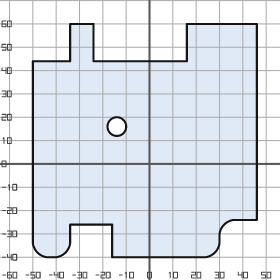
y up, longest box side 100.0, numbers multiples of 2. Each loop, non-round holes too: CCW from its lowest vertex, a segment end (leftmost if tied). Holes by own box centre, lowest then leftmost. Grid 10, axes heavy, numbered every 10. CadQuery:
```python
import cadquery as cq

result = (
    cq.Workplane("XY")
    .moveTo(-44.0, -40.0)
    .lineTo(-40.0, -40.0)
    .threePointArc((-36.0, -38.0), (-34.0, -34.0))
    .lineTo(-34.0, -26.0)
    .lineTo(-16.0, -26.0)
    .lineTo(-16.0, -40.0)
    .lineTo(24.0, -40.0)
    .threePointArc((28.0, -38.0), (30.0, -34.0))
    .lineTo(30.0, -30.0)
    .threePointArc((32.0, -26.0), (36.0, -24.0))
    .lineTo(46.0, -24.0)
    .lineTo(46.0, 60.0)
    .lineTo(16.0, 60.0)
    .lineTo(16.0, 44.0)
    .lineTo(-24.0, 44.0)
    .lineTo(-24.0, 60.0)
    .lineTo(-34.0, 60.0)
    .lineTo(-34.0, 44.0)
    .lineTo(-50.0, 44.0)
    .lineTo(-50.0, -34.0)
    .threePointArc((-48.0, -38.0), (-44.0, -40.0))
    .close()
    .moveTo(-14.0, 16.0)
    .circle(4.0)
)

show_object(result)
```